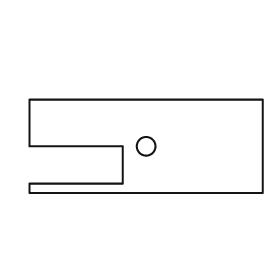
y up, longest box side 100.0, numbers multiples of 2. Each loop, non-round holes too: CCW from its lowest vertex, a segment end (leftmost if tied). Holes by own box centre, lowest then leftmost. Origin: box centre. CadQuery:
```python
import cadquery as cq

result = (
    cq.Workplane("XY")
    .moveTo(-50.0, -20.0)
    .lineTo(50.0, -20.0)
    .lineTo(50.0, 20.0)
    .lineTo(-50.0, 20.0)
    .lineTo(-50.0, 0.0)
    .lineTo(-10.0, 0.0)
    .lineTo(-10.0, -16.0)
    .lineTo(-50.0, -16.0)
    .close()
    .moveTo(0.0, 0.0)
    .circle(4.0)
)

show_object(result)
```